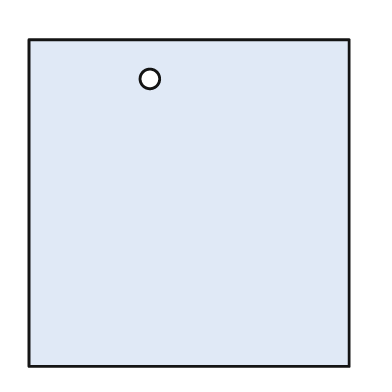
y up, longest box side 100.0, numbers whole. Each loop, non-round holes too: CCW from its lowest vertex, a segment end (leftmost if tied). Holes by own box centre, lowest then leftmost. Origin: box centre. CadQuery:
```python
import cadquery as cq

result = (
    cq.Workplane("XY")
    .moveTo(-49.0, -50.0)
    .lineTo(49.0, -50.0)
    .lineTo(49.0, 50.0)
    .lineTo(-49.0, 50.0)
    .close()
    .moveTo(-12.0, 38.0)
    .circle(3.0)
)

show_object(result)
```